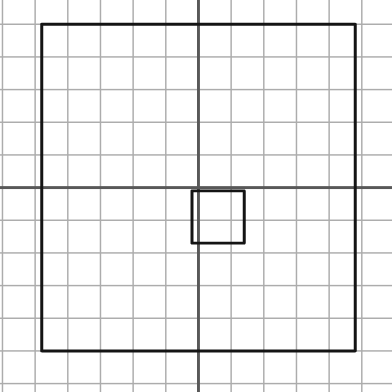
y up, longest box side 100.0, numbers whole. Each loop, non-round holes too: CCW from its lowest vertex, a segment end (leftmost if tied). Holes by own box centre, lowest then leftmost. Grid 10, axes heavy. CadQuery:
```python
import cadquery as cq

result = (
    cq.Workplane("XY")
    .moveTo(-48.0, -50.0)
    .lineTo(48.0, -50.0)
    .lineTo(48.0, 50.0)
    .lineTo(-48.0, 50.0)
    .close()
    .moveTo(-2.0, -17.0)
    .lineTo(14.0, -17.0)
    .lineTo(14.0, -1.0)
    .lineTo(-2.0, -1.0)
    .close()
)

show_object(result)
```